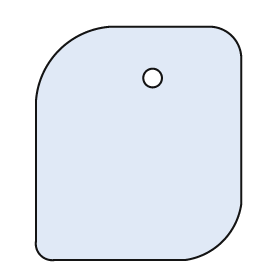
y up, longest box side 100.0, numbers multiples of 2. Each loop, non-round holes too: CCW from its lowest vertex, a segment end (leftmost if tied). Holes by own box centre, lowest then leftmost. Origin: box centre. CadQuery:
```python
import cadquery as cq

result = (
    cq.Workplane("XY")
    .moveTo(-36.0, -50.0)
    .lineTo(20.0, -50.0)
    .threePointArc((36.0, -42.0), (44.0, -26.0))
    .lineTo(44.0, 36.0)
    .threePointArc((40.0, 46.0), (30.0, 50.0))
    .lineTo(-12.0, 50.0)
    .threePointArc((-34.0, 40.0), (-44.0, 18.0))
    .lineTo(-44.0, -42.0)
    .threePointArc((-42.0, -48.0), (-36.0, -50.0))
    .close()
    .moveTo(6.0, 28.0)
    .circle(4.0)
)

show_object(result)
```